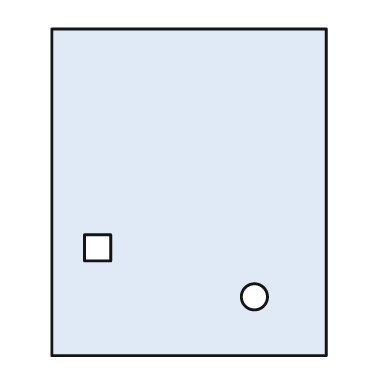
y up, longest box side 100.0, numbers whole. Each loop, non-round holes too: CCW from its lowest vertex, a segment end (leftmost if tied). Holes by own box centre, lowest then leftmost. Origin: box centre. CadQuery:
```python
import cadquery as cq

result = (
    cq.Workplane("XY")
    .moveTo(-42.0, -50.0)
    .lineTo(42.0, -50.0)
    .lineTo(42.0, 50.0)
    .lineTo(-42.0, 50.0)
    .close()
    .moveTo(20.0, -32.0)
    .circle(4.0)
    .moveTo(-32.0, -21.0)
    .lineTo(-24.0, -21.0)
    .lineTo(-24.0, -13.0)
    .lineTo(-32.0, -13.0)
    .close()
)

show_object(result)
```